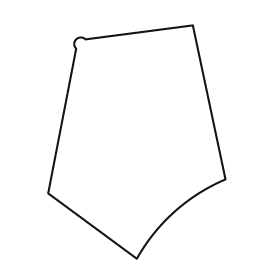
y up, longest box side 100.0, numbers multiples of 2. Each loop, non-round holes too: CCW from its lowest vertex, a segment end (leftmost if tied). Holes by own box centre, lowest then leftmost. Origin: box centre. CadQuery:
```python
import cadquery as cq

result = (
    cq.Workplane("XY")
    .moveTo(0.0, -50.0)
    .threePointArc((16.0, -30.0), (38.0, -16.0))
    .lineTo(24.0, 50.0)
    .lineTo(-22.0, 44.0)
    .threePointArc((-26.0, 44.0), (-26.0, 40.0))
    .lineTo(-38.0, -22.0)
    .close()
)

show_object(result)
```